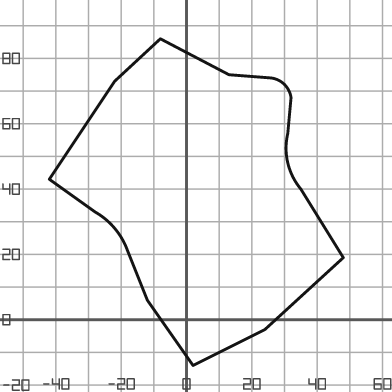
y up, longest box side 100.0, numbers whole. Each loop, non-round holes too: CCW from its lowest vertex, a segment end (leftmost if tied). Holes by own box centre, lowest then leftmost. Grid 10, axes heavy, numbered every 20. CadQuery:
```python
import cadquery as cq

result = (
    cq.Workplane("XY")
    .moveTo(2.0, -14.0)
    .lineTo(24.0, -3.0)
    .lineTo(48.0, 19.0)
    .lineTo(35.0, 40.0)
    .threePointArc((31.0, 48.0), (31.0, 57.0))
    .lineTo(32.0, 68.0)
    .threePointArc((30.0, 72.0), (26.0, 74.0))
    .lineTo(13.0, 75.0)
    .lineTo(-8.0, 86.0)
    .lineTo(-22.0, 73.0)
    .lineTo(-42.0, 43.0)
    .lineTo(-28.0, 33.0)
    .threePointArc((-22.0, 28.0), (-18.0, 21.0))
    .lineTo(-12.0, 6.0)
    .close()
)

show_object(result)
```